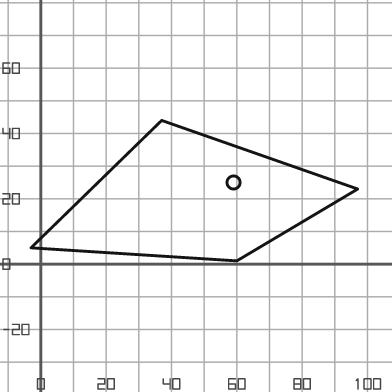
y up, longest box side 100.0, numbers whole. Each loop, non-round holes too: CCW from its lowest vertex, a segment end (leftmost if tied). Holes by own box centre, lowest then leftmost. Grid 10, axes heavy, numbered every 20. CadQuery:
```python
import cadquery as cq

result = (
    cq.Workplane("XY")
    .moveTo(60.0, 1.0)
    .lineTo(97.0, 23.0)
    .lineTo(37.0, 44.0)
    .lineTo(-3.0, 5.0)
    .close()
    .moveTo(59.0, 25.0)
    .circle(2.0)
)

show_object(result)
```